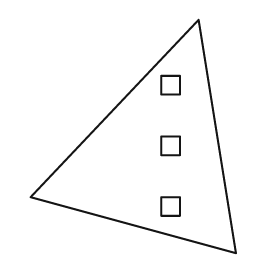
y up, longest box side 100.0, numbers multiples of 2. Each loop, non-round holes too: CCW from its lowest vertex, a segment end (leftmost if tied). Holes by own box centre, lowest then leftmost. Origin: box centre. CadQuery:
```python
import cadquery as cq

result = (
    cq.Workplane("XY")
    .moveTo(44.0, -50.0)
    .lineTo(28.0, 50.0)
    .lineTo(-44.0, -26.0)
    .close()
    .moveTo(12.0, -34.0)
    .lineTo(20.0, -34.0)
    .lineTo(20.0, -26.0)
    .lineTo(12.0, -26.0)
    .close()
    .moveTo(12.0, -8.0)
    .lineTo(20.0, -8.0)
    .lineTo(20.0, 0.0)
    .lineTo(12.0, 0.0)
    .close()
    .moveTo(12.0, 18.0)
    .lineTo(20.0, 18.0)
    .lineTo(20.0, 26.0)
    .lineTo(12.0, 26.0)
    .close()
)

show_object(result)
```